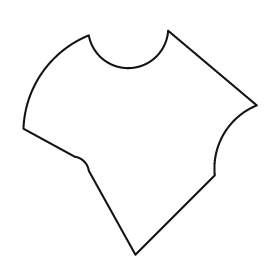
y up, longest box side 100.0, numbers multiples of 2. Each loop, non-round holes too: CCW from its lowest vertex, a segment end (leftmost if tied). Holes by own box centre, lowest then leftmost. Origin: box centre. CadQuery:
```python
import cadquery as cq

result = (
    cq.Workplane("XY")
    .moveTo(-2.0, -48.0)
    .lineTo(32.0, -14.0)
    .threePointArc((36.0, 4.0), (50.0, 16.0))
    .lineTo(12.0, 48.0)
    .threePointArc((-4.0, 32.0), (-22.0, 46.0))
    .threePointArc((-42.0, 30.0), (-50.0, 6.0))
    .lineTo(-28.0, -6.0)
    .threePointArc((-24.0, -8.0), (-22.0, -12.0))
    .close()
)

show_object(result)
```